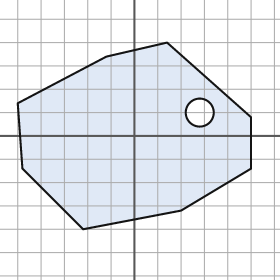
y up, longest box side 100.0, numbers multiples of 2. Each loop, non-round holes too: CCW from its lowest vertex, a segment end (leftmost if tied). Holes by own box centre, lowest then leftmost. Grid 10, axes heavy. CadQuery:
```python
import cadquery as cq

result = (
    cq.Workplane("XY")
    .moveTo(-22.0, -40.0)
    .lineTo(20.0, -32.0)
    .lineTo(50.0, -14.0)
    .lineTo(50.0, 8.0)
    .lineTo(14.0, 40.0)
    .lineTo(-12.0, 34.0)
    .lineTo(-50.0, 14.0)
    .lineTo(-48.0, -14.0)
    .close()
    .moveTo(28.0, 10.0)
    .circle(6.0)
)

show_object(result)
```